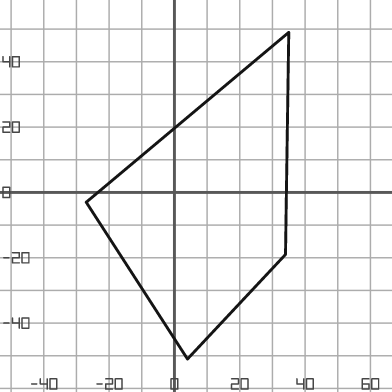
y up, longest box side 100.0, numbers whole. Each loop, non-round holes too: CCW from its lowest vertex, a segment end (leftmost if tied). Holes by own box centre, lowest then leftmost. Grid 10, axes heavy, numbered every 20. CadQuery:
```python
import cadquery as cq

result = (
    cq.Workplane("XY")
    .moveTo(4.0, -51.0)
    .lineTo(34.0, -19.0)
    .lineTo(35.0, 49.0)
    .lineTo(-27.0, -3.0)
    .close()
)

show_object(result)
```